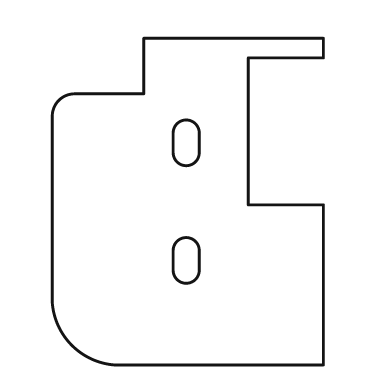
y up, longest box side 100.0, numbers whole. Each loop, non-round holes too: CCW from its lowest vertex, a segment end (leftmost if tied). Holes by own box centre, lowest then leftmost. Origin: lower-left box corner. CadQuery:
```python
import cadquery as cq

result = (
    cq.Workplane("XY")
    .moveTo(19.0, 0.0)
    .lineTo(83.0, 0.0)
    .lineTo(83.0, 49.0)
    .lineTo(60.0, 49.0)
    .lineTo(60.0, 94.0)
    .lineTo(83.0, 94.0)
    .lineTo(83.0, 100.0)
    .lineTo(28.0, 100.0)
    .lineTo(28.0, 83.0)
    .lineTo(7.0, 83.0)
    .threePointArc((2.0, 81.0), (0.0, 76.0))
    .lineTo(0.0, 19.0)
    .threePointArc((6.0, 6.0), (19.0, 0.0))
    .close()
    .moveTo(37.0, 29.0)
    .threePointArc((41.0, 25.0), (45.0, 29.0))
    .lineTo(45.0, 35.0)
    .threePointArc((41.0, 39.0), (37.0, 35.0))
    .close()
    .moveTo(37.0, 65.0)
    .threePointArc((41.0, 61.0), (45.0, 65.0))
    .lineTo(45.0, 71.0)
    .threePointArc((41.0, 75.0), (37.0, 71.0))
    .close()
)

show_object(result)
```